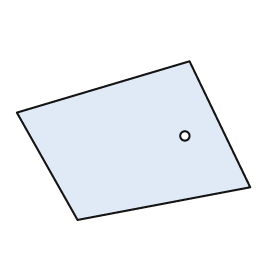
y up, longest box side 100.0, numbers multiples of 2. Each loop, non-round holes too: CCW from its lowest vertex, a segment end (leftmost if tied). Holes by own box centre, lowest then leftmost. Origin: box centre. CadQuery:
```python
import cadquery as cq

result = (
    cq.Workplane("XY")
    .moveTo(-24.0, -34.0)
    .lineTo(50.0, -20.0)
    .lineTo(24.0, 34.0)
    .lineTo(-50.0, 12.0)
    .close()
    .moveTo(22.0, 2.0)
    .circle(2.0)
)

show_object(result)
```